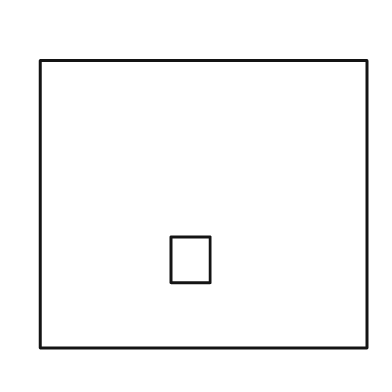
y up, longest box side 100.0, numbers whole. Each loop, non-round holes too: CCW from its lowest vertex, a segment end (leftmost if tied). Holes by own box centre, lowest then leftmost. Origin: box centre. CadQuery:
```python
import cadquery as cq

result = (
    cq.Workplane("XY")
    .moveTo(-50.0, -44.0)
    .lineTo(50.0, -44.0)
    .lineTo(50.0, 44.0)
    .lineTo(-50.0, 44.0)
    .close()
    .moveTo(-10.0, -24.0)
    .lineTo(2.0, -24.0)
    .lineTo(2.0, -10.0)
    .lineTo(-10.0, -10.0)
    .close()
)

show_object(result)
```